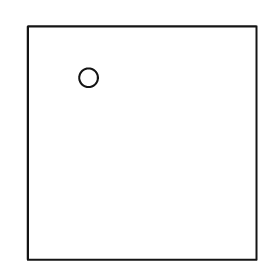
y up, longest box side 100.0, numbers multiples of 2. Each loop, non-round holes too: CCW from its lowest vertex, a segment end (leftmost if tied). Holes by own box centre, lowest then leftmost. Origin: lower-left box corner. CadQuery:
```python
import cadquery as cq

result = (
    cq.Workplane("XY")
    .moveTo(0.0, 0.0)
    .lineTo(98.0, 0.0)
    .lineTo(98.0, 100.0)
    .lineTo(0.0, 100.0)
    .close()
    .moveTo(26.0, 78.0)
    .circle(4.0)
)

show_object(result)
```